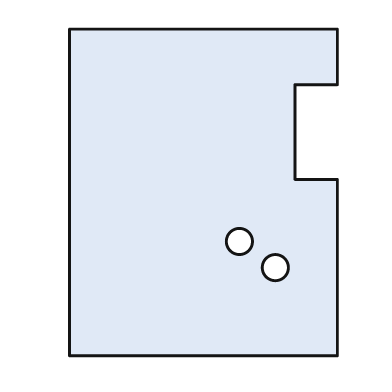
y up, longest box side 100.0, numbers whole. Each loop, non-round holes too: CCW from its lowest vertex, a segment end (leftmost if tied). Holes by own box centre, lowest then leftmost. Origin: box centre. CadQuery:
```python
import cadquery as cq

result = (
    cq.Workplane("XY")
    .moveTo(-41.0, -50.0)
    .lineTo(41.0, -50.0)
    .lineTo(41.0, 4.0)
    .lineTo(28.0, 4.0)
    .lineTo(28.0, 33.0)
    .lineTo(41.0, 33.0)
    .lineTo(41.0, 50.0)
    .lineTo(-41.0, 50.0)
    .close()
    .moveTo(22.0, -23.0)
    .circle(4.0)
    .moveTo(11.0, -15.0)
    .circle(4.0)
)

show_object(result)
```